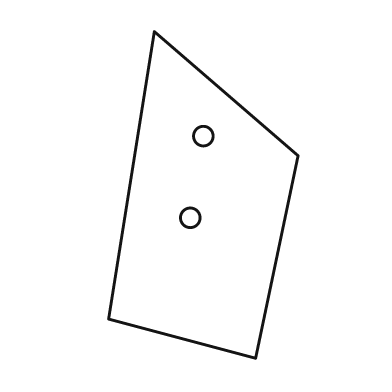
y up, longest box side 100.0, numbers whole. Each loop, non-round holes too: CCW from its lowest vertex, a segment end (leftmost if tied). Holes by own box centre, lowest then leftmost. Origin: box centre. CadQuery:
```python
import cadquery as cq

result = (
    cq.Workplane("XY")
    .moveTo(16.0, -50.0)
    .lineTo(29.0, 12.0)
    .lineTo(-15.0, 50.0)
    .lineTo(-29.0, -38.0)
    .close()
    .moveTo(-4.0, -7.0)
    .circle(3.0)
    .moveTo(0.0, 18.0)
    .circle(3.0)
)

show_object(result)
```